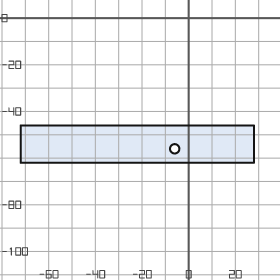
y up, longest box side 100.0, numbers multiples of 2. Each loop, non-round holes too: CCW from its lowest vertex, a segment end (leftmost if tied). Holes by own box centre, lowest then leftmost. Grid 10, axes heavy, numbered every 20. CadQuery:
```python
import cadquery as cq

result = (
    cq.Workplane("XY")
    .moveTo(-72.0, -62.0)
    .lineTo(28.0, -62.0)
    .lineTo(28.0, -46.0)
    .lineTo(-72.0, -46.0)
    .close()
    .moveTo(-6.0, -56.0)
    .circle(2.0)
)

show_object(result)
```